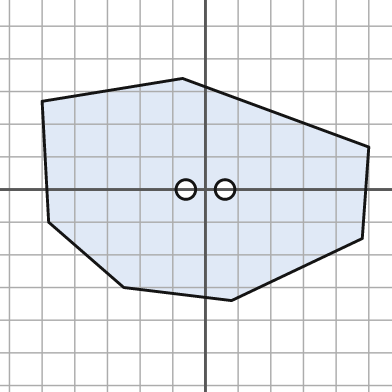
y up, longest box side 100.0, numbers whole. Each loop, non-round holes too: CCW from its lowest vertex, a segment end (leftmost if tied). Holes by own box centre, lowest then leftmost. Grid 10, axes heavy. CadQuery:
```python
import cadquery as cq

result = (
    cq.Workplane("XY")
    .moveTo(8.0, -34.0)
    .lineTo(48.0, -15.0)
    .lineTo(50.0, 13.0)
    .lineTo(-7.0, 34.0)
    .lineTo(-50.0, 27.0)
    .lineTo(-48.0, -10.0)
    .lineTo(-25.0, -30.0)
    .close()
    .moveTo(-6.0, 0.0)
    .circle(3.0)
    .moveTo(6.0, 0.0)
    .circle(3.0)
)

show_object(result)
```